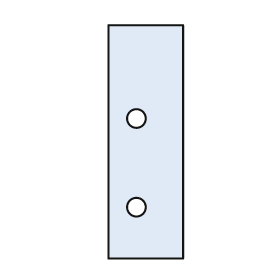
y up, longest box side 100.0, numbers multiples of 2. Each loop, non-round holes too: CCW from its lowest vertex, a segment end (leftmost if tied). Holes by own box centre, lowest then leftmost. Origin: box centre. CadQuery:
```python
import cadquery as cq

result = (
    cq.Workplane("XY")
    .moveTo(-16.0, -50.0)
    .lineTo(16.0, -50.0)
    .lineTo(16.0, 50.0)
    .lineTo(-16.0, 50.0)
    .close()
    .moveTo(-4.0, -28.0)
    .circle(4.0)
    .moveTo(-4.0, 10.0)
    .circle(4.0)
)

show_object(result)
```